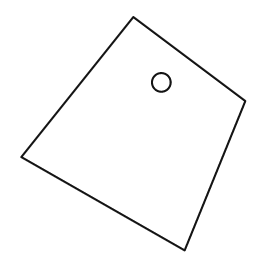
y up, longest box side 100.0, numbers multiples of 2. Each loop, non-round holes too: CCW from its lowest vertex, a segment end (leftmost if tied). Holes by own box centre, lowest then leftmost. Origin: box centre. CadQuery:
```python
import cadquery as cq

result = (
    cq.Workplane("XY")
    .moveTo(22.0, -50.0)
    .lineTo(48.0, 14.0)
    .lineTo(0.0, 50.0)
    .lineTo(-48.0, -10.0)
    .close()
    .moveTo(12.0, 22.0)
    .circle(4.0)
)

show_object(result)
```